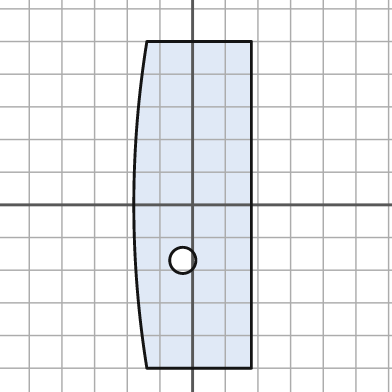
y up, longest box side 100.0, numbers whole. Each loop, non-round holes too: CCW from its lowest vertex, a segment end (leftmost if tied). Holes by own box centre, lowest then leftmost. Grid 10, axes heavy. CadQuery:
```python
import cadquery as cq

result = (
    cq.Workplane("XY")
    .moveTo(-14.0, -50.0)
    .lineTo(18.0, -50.0)
    .lineTo(18.0, 50.0)
    .lineTo(-14.0, 50.0)
    .threePointArc((-18.0, 0.0), (-14.0, -50.0))
    .close()
    .moveTo(-3.0, -17.0)
    .circle(4.0)
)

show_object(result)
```